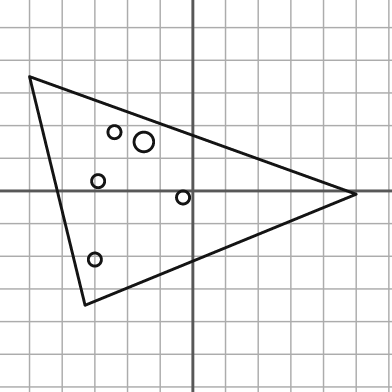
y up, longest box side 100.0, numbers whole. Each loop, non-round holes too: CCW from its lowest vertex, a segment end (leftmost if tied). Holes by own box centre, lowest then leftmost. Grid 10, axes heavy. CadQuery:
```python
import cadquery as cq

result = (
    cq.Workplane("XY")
    .moveTo(-33.0, -35.0)
    .lineTo(50.0, -1.0)
    .lineTo(-50.0, 35.0)
    .close()
    .moveTo(-30.0, -21.0)
    .circle(2.0)
    .moveTo(-3.0, -2.0)
    .circle(2.0)
    .moveTo(-29.0, 3.0)
    .circle(2.0)
    .moveTo(-15.0, 15.0)
    .circle(3.0)
    .moveTo(-24.0, 18.0)
    .circle(2.0)
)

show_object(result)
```